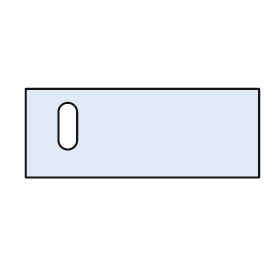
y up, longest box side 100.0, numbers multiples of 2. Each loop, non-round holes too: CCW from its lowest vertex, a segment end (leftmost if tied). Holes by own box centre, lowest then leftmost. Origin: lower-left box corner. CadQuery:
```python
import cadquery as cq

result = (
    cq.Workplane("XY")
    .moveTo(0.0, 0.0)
    .lineTo(100.0, 0.0)
    .lineTo(100.0, 38.0)
    .lineTo(0.0, 38.0)
    .close()
    .moveTo(14.0, 16.0)
    .threePointArc((18.0, 12.0), (22.0, 16.0))
    .lineTo(22.0, 28.0)
    .threePointArc((18.0, 32.0), (14.0, 28.0))
    .close()
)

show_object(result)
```